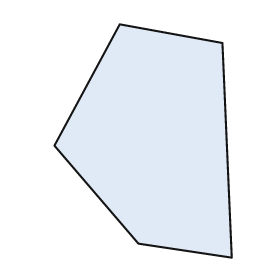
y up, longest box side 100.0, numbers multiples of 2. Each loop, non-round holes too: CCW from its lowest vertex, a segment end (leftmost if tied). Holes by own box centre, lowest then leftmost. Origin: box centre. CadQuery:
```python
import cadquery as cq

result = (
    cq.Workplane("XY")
    .moveTo(38.0, -50.0)
    .lineTo(34.0, 42.0)
    .lineTo(-10.0, 50.0)
    .lineTo(-38.0, -2.0)
    .lineTo(-2.0, -44.0)
    .close()
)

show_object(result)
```